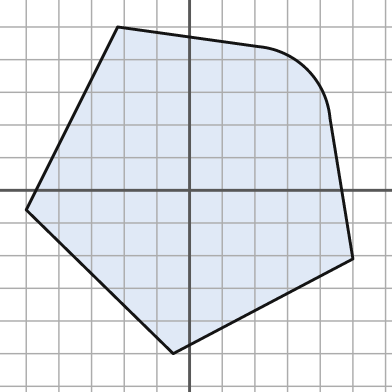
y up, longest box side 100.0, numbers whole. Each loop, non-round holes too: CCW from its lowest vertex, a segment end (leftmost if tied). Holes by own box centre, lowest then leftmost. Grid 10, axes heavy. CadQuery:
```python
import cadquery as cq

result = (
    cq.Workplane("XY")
    .moveTo(-5.0, -50.0)
    .lineTo(50.0, -21.0)
    .lineTo(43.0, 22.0)
    .threePointArc((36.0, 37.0), (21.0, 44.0))
    .lineTo(-22.0, 50.0)
    .lineTo(-50.0, -6.0)
    .close()
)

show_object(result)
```